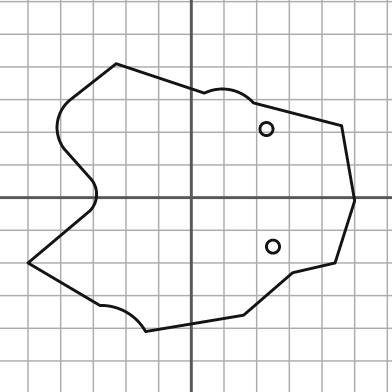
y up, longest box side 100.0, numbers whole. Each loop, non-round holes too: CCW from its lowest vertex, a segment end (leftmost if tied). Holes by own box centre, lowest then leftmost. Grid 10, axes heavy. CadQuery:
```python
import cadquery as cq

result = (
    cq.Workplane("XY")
    .moveTo(-14.0, -41.0)
    .lineTo(16.0, -36.0)
    .lineTo(31.0, -23.0)
    .lineTo(44.0, -20.0)
    .lineTo(50.0, -1.0)
    .lineTo(46.0, 22.0)
    .lineTo(19.0, 29.0)
    .threePointArc((12.0, 33.0), (4.0, 32.0))
    .lineTo(-23.0, 41.0)
    .lineTo(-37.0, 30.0)
    .threePointArc((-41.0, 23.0), (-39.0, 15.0))
    .lineTo(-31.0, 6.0)
    .threePointArc((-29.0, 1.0), (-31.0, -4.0))
    .lineTo(-50.0, -20.0)
    .lineTo(-28.0, -33.0)
    .threePointArc((-20.0, -35.0), (-14.0, -41.0))
    .close()
    .moveTo(25.0, -15.0)
    .circle(2.0)
    .moveTo(23.0, 21.0)
    .circle(2.0)
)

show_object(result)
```